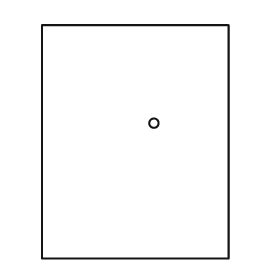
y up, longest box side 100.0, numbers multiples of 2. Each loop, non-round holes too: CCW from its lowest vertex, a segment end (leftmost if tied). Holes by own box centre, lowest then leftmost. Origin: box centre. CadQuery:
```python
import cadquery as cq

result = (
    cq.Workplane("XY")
    .moveTo(-40.0, -50.0)
    .lineTo(40.0, -50.0)
    .lineTo(40.0, 50.0)
    .lineTo(-40.0, 50.0)
    .close()
    .moveTo(8.0, 8.0)
    .circle(2.0)
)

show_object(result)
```